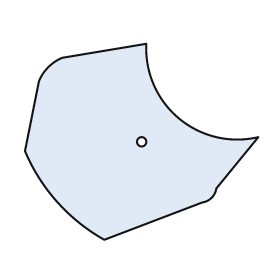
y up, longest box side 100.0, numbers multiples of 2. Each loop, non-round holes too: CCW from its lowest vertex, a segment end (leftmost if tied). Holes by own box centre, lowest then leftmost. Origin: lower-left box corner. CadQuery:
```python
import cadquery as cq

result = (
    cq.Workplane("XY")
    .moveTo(34.0, 0.0)
    .lineTo(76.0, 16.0)
    .threePointArc((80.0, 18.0), (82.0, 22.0))
    .lineTo(100.0, 44.0)
    .threePointArc((66.0, 52.0), (52.0, 84.0))
    .lineTo(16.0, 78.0)
    .threePointArc((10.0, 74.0), (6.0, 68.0))
    .lineTo(0.0, 38.0)
    .threePointArc((14.0, 16.0), (34.0, 0.0))
    .close()
    .moveTo(50.0, 42.0)
    .circle(2.0)
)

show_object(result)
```